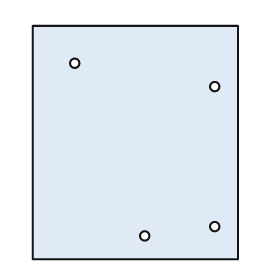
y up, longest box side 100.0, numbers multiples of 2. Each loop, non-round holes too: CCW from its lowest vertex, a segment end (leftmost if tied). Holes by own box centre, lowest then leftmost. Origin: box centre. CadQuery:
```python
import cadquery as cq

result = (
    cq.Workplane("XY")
    .moveTo(-44.0, -50.0)
    .lineTo(44.0, -50.0)
    .lineTo(44.0, 50.0)
    .lineTo(-44.0, 50.0)
    .close()
    .moveTo(4.0, -40.0)
    .circle(2.0)
    .moveTo(34.0, -36.0)
    .circle(2.0)
    .moveTo(34.0, 24.0)
    .circle(2.0)
    .moveTo(-26.0, 34.0)
    .circle(2.0)
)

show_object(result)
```